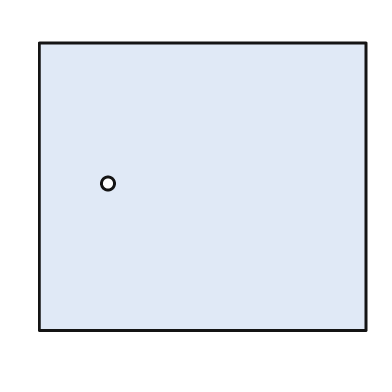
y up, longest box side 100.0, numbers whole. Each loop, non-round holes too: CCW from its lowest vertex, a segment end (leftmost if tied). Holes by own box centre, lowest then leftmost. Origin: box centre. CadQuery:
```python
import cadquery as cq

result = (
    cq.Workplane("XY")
    .moveTo(-50.0, -44.0)
    .lineTo(50.0, -44.0)
    .lineTo(50.0, 44.0)
    .lineTo(-50.0, 44.0)
    .close()
    .moveTo(-29.0, 1.0)
    .circle(2.0)
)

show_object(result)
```